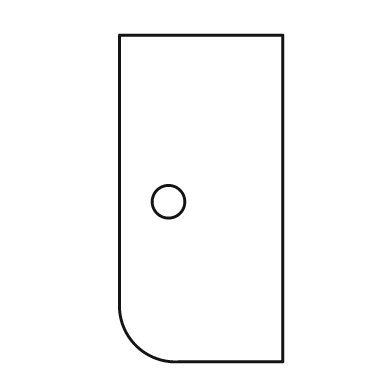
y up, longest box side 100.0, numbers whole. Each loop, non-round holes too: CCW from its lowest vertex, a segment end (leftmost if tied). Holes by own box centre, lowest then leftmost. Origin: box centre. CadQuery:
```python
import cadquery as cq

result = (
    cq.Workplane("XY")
    .moveTo(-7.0, -50.0)
    .lineTo(25.0, -50.0)
    .lineTo(25.0, 50.0)
    .lineTo(-25.0, 50.0)
    .lineTo(-25.0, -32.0)
    .threePointArc((-20.0, -45.0), (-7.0, -50.0))
    .close()
    .moveTo(-10.0, -1.0)
    .circle(5.0)
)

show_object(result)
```